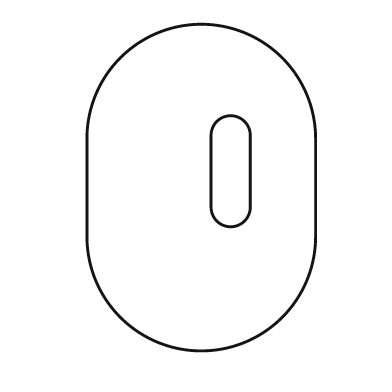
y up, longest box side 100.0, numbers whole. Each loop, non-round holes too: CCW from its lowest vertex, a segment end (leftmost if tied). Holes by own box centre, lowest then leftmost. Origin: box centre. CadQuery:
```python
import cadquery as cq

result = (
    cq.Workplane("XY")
    .moveTo(-35.0, -15.0)
    .threePointArc((0.0, -50.0), (35.0, -15.0))
    .lineTo(35.0, 15.0)
    .threePointArc((0.0, 50.0), (-35.0, 15.0))
    .close()
    .moveTo(3.0, -6.0)
    .threePointArc((9.0, -12.0), (15.0, -6.0))
    .lineTo(15.0, 16.0)
    .threePointArc((9.0, 22.0), (3.0, 16.0))
    .close()
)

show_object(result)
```